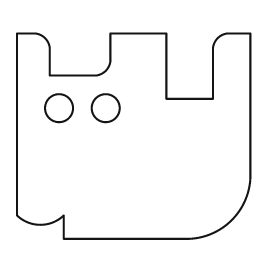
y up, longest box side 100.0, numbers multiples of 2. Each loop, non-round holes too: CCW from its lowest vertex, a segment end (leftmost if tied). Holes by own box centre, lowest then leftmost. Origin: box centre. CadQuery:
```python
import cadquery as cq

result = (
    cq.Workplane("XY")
    .moveTo(-30.0, -44.0)
    .lineTo(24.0, -44.0)
    .threePointArc((42.0, -36.0), (50.0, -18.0))
    .lineTo(50.0, 44.0)
    .lineTo(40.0, 44.0)
    .threePointArc((36.0, 42.0), (34.0, 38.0))
    .lineTo(34.0, 16.0)
    .lineTo(14.0, 16.0)
    .lineTo(14.0, 44.0)
    .lineTo(-10.0, 44.0)
    .lineTo(-10.0, 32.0)
    .threePointArc((-12.0, 28.0), (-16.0, 26.0))
    .lineTo(-36.0, 26.0)
    .lineTo(-36.0, 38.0)
    .threePointArc((-38.0, 42.0), (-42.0, 44.0))
    .lineTo(-50.0, 44.0)
    .lineTo(-50.0, -34.0)
    .threePointArc((-40.0, -38.0), (-30.0, -34.0))
    .close()
    .moveTo(-32.0, 12.0)
    .circle(6.0)
    .moveTo(-12.0, 12.0)
    .circle(6.0)
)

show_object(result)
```